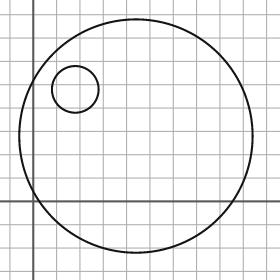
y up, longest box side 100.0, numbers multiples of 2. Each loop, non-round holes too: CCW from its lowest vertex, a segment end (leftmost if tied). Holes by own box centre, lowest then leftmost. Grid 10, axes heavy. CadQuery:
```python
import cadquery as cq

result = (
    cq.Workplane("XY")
    .moveTo(44.0, 28.0)
    .circle(50.0)
    .moveTo(18.0, 48.0)
    .circle(10.0)
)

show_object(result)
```